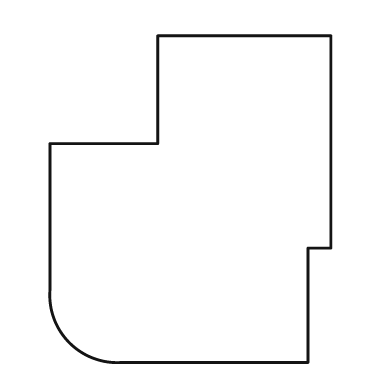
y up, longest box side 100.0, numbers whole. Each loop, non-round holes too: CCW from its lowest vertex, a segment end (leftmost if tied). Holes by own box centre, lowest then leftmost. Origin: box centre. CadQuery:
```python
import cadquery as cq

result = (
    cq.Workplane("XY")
    .moveTo(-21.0, -50.0)
    .lineTo(36.0, -50.0)
    .lineTo(36.0, -15.0)
    .lineTo(43.0, -15.0)
    .lineTo(43.0, 50.0)
    .lineTo(-10.0, 50.0)
    .lineTo(-10.0, 17.0)
    .lineTo(-43.0, 17.0)
    .lineTo(-43.0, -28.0)
    .threePointArc((-37.0, -44.0), (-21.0, -50.0))
    .close()
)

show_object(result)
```